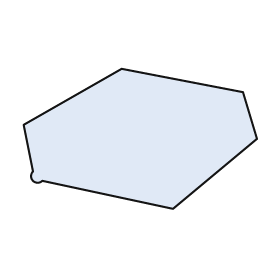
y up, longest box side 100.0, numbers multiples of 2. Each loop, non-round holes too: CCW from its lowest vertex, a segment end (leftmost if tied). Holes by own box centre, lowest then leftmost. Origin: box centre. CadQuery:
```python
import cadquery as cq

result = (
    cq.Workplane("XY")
    .moveTo(14.0, -30.0)
    .lineTo(50.0, 0.0)
    .lineTo(44.0, 20.0)
    .lineTo(-8.0, 30.0)
    .lineTo(-50.0, 6.0)
    .lineTo(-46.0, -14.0)
    .threePointArc((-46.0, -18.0), (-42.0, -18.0))
    .close()
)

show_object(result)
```